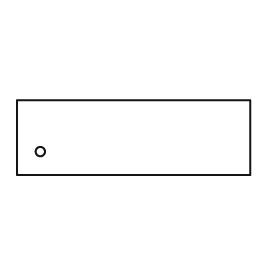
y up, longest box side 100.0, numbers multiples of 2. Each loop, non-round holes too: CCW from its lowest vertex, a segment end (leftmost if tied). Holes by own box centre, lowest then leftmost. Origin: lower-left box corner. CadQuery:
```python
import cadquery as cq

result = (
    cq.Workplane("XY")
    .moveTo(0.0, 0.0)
    .lineTo(100.0, 0.0)
    .lineTo(100.0, 32.0)
    .lineTo(0.0, 32.0)
    .close()
    .moveTo(10.0, 10.0)
    .circle(2.0)
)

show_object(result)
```